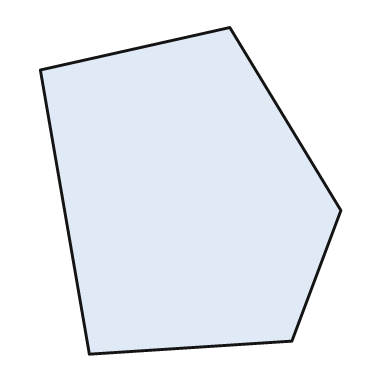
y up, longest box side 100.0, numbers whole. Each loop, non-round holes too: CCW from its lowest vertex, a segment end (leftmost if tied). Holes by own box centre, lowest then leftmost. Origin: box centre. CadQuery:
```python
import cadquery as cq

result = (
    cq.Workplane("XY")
    .moveTo(-31.0, -50.0)
    .lineTo(31.0, -46.0)
    .lineTo(46.0, -6.0)
    .lineTo(12.0, 50.0)
    .lineTo(-46.0, 37.0)
    .close()
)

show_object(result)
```